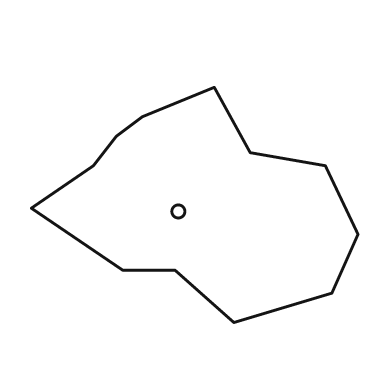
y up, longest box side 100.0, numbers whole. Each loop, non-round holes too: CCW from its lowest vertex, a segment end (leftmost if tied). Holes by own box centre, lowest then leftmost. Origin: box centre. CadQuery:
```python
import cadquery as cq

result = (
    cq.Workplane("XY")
    .moveTo(12.0, -36.0)
    .lineTo(42.0, -27.0)
    .lineTo(50.0, -9.0)
    .lineTo(40.0, 12.0)
    .lineTo(17.0, 16.0)
    .lineTo(6.0, 36.0)
    .lineTo(-16.0, 27.0)
    .lineTo(-24.0, 21.0)
    .lineTo(-31.0, 12.0)
    .lineTo(-50.0, -1.0)
    .lineTo(-22.0, -20.0)
    .lineTo(-6.0, -20.0)
    .close()
    .moveTo(-5.0, -2.0)
    .circle(2.0)
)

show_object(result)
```